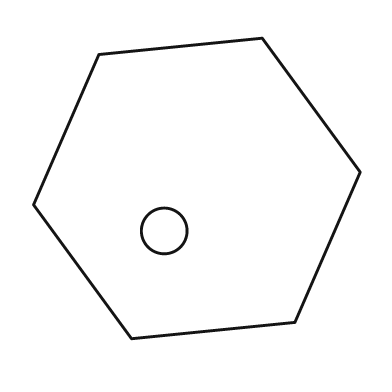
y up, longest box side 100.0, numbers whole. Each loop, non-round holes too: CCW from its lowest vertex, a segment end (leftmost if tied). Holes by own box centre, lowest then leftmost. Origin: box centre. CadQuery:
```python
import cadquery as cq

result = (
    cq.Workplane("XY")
    .moveTo(-20.0, -46.0)
    .lineTo(30.0, -41.0)
    .lineTo(50.0, 5.0)
    .lineTo(20.0, 46.0)
    .lineTo(-30.0, 41.0)
    .lineTo(-50.0, -5.0)
    .close()
    .moveTo(-10.0, -13.0)
    .circle(7.0)
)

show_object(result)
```